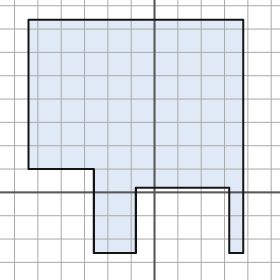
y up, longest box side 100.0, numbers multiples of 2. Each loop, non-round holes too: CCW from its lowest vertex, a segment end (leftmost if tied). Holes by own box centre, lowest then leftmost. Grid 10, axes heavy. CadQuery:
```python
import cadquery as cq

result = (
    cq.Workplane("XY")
    .moveTo(-26.0, -26.0)
    .lineTo(-8.0, -26.0)
    .lineTo(-8.0, 2.0)
    .lineTo(32.0, 2.0)
    .lineTo(32.0, -26.0)
    .lineTo(38.0, -26.0)
    .lineTo(38.0, 74.0)
    .lineTo(-54.0, 74.0)
    .lineTo(-54.0, 10.0)
    .lineTo(-26.0, 10.0)
    .close()
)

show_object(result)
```